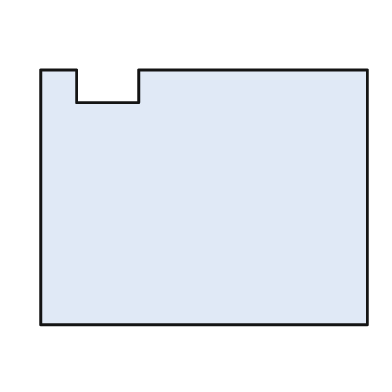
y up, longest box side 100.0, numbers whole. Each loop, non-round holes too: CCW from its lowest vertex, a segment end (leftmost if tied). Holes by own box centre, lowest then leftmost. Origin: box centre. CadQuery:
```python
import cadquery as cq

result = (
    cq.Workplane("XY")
    .moveTo(-50.0, -39.0)
    .lineTo(50.0, -39.0)
    .lineTo(50.0, 39.0)
    .lineTo(-20.0, 39.0)
    .lineTo(-20.0, 29.0)
    .lineTo(-39.0, 29.0)
    .lineTo(-39.0, 39.0)
    .lineTo(-50.0, 39.0)
    .close()
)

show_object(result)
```